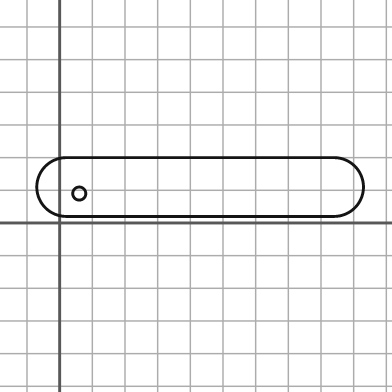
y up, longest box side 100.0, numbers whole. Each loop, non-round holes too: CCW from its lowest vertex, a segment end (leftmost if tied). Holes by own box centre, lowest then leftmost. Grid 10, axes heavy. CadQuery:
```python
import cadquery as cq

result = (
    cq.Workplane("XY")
    .moveTo(2.0, 2.0)
    .lineTo(84.0, 2.0)
    .threePointArc((93.0, 11.0), (84.0, 20.0))
    .lineTo(2.0, 20.0)
    .threePointArc((-7.0, 11.0), (2.0, 2.0))
    .close()
    .moveTo(6.0, 9.0)
    .circle(2.0)
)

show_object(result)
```